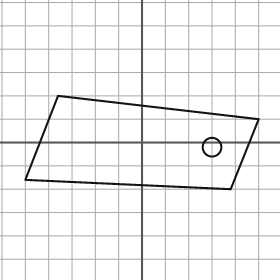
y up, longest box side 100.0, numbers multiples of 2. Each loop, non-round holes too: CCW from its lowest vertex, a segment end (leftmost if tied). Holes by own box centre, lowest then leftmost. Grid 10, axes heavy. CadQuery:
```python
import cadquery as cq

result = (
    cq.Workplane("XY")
    .moveTo(38.0, -20.0)
    .lineTo(50.0, 10.0)
    .lineTo(-36.0, 20.0)
    .lineTo(-50.0, -16.0)
    .close()
    .moveTo(30.0, -2.0)
    .circle(4.0)
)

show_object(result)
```